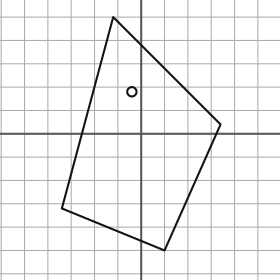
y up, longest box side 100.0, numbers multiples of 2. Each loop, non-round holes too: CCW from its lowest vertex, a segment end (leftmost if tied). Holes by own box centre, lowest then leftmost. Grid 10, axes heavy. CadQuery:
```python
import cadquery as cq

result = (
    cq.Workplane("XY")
    .moveTo(10.0, -50.0)
    .lineTo(34.0, 4.0)
    .lineTo(-12.0, 50.0)
    .lineTo(-34.0, -32.0)
    .close()
    .moveTo(-4.0, 18.0)
    .circle(2.0)
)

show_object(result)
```